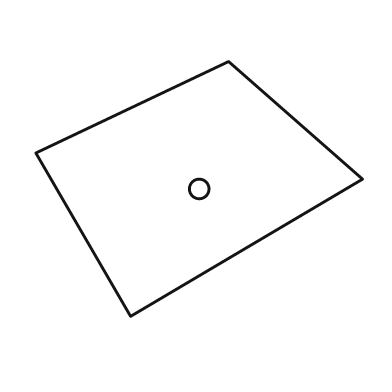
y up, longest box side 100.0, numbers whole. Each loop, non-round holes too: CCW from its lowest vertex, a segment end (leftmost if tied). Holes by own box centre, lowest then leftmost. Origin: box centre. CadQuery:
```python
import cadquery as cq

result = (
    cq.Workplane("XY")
    .moveTo(-21.0, -39.0)
    .lineTo(50.0, 3.0)
    .lineTo(9.0, 39.0)
    .lineTo(-50.0, 11.0)
    .close()
    .moveTo(0.0, 0.0)
    .circle(3.0)
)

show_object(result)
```